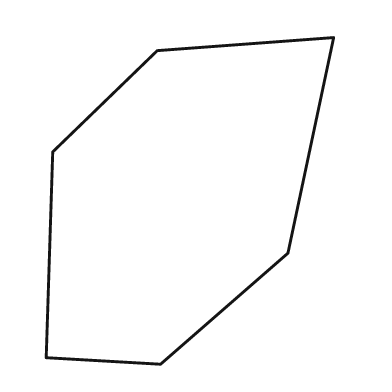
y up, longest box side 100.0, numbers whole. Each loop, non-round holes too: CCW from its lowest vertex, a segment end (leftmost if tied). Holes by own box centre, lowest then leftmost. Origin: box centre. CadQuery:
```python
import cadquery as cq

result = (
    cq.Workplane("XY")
    .moveTo(-9.0, -50.0)
    .lineTo(30.0, -16.0)
    .lineTo(44.0, 50.0)
    .lineTo(-10.0, 46.0)
    .lineTo(-42.0, 15.0)
    .lineTo(-44.0, -48.0)
    .close()
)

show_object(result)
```